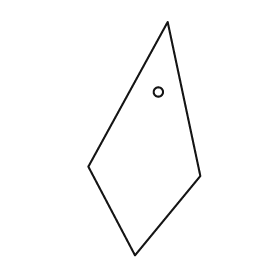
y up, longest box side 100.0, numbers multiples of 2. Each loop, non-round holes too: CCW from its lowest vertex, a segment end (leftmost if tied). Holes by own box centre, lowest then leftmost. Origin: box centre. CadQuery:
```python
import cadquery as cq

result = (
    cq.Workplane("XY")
    .moveTo(-4.0, -50.0)
    .lineTo(24.0, -16.0)
    .lineTo(10.0, 50.0)
    .lineTo(-24.0, -12.0)
    .close()
    .moveTo(6.0, 20.0)
    .circle(2.0)
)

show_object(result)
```